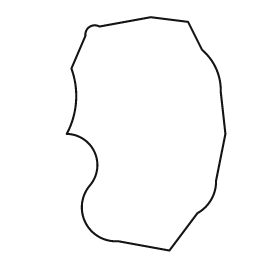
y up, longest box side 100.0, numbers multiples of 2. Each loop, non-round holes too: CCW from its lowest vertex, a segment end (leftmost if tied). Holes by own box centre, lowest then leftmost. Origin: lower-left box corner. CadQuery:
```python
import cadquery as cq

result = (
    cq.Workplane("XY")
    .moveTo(44.0, 0.0)
    .lineTo(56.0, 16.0)
    .threePointArc((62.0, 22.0), (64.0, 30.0))
    .lineTo(68.0, 50.0)
    .lineTo(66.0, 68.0)
    .threePointArc((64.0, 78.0), (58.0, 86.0))
    .lineTo(52.0, 98.0)
    .lineTo(36.0, 100.0)
    .lineTo(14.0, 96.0)
    .threePointArc((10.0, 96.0), (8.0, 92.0))
    .lineTo(2.0, 78.0)
    .threePointArc((4.0, 64.0), (0.0, 50.0))
    .threePointArc((12.0, 42.0), (10.0, 28.0))
    .threePointArc((8.0, 12.0), (22.0, 4.0))
    .close()
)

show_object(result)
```